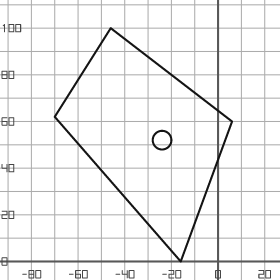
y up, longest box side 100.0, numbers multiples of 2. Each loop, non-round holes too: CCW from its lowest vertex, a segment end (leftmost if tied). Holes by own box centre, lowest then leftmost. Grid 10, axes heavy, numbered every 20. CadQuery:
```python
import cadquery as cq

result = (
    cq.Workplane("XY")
    .moveTo(-16.0, 0.0)
    .lineTo(6.0, 60.0)
    .lineTo(-46.0, 100.0)
    .lineTo(-70.0, 62.0)
    .close()
    .moveTo(-24.0, 52.0)
    .circle(4.0)
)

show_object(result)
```